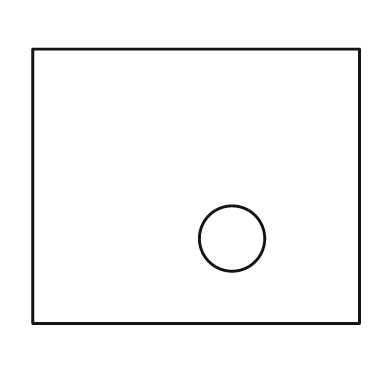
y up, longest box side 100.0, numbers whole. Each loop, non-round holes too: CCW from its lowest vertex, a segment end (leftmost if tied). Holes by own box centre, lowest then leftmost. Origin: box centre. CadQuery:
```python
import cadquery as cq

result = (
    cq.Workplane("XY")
    .moveTo(-50.0, -42.0)
    .lineTo(50.0, -42.0)
    .lineTo(50.0, 42.0)
    .lineTo(-50.0, 42.0)
    .close()
    .moveTo(11.0, -16.0)
    .circle(10.0)
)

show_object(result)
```